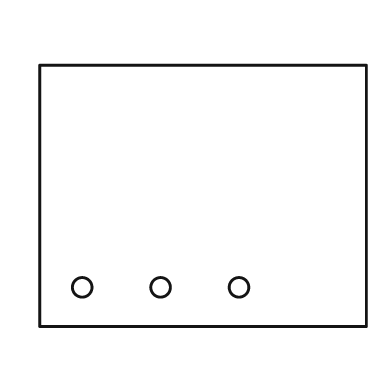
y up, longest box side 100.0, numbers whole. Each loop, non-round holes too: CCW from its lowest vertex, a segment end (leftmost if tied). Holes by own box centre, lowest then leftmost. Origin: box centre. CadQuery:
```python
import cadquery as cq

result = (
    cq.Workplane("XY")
    .moveTo(-50.0, -40.0)
    .lineTo(50.0, -40.0)
    .lineTo(50.0, 40.0)
    .lineTo(-50.0, 40.0)
    .close()
    .moveTo(-37.0, -28.0)
    .circle(3.0)
    .moveTo(-13.0, -28.0)
    .circle(3.0)
    .moveTo(11.0, -28.0)
    .circle(3.0)
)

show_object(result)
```